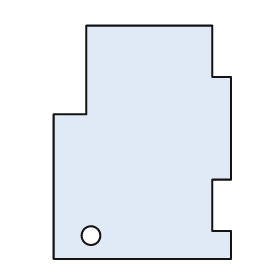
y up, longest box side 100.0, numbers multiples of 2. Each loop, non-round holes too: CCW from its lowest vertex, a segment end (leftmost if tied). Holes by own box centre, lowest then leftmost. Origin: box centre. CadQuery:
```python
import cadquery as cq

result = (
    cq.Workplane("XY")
    .moveTo(-38.0, -50.0)
    .lineTo(38.0, -50.0)
    .lineTo(38.0, -38.0)
    .lineTo(30.0, -38.0)
    .lineTo(30.0, -16.0)
    .lineTo(38.0, -16.0)
    .lineTo(38.0, 28.0)
    .lineTo(30.0, 28.0)
    .lineTo(30.0, 50.0)
    .lineTo(-24.0, 50.0)
    .lineTo(-24.0, 12.0)
    .lineTo(-38.0, 12.0)
    .close()
    .moveTo(-22.0, -40.0)
    .circle(4.0)
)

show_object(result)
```